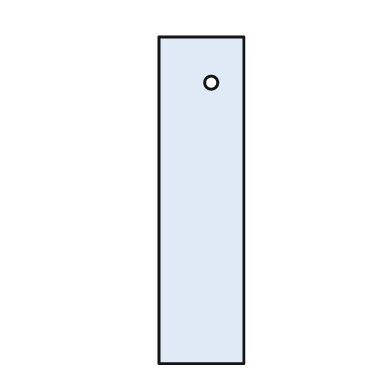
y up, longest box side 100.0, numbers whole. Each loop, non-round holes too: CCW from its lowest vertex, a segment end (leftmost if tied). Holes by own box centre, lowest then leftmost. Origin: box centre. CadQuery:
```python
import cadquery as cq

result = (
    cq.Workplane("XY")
    .moveTo(-13.0, -50.0)
    .lineTo(13.0, -50.0)
    .lineTo(13.0, 50.0)
    .lineTo(-13.0, 50.0)
    .close()
    .moveTo(3.0, 36.0)
    .circle(2.0)
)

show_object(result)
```